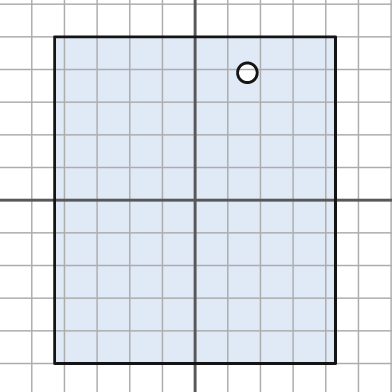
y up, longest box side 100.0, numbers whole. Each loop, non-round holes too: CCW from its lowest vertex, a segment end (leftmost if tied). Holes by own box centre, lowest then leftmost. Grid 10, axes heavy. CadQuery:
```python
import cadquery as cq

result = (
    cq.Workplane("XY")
    .moveTo(-43.0, -50.0)
    .lineTo(43.0, -50.0)
    .lineTo(43.0, 50.0)
    .lineTo(-43.0, 50.0)
    .close()
    .moveTo(16.0, 39.0)
    .circle(3.0)
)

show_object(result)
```